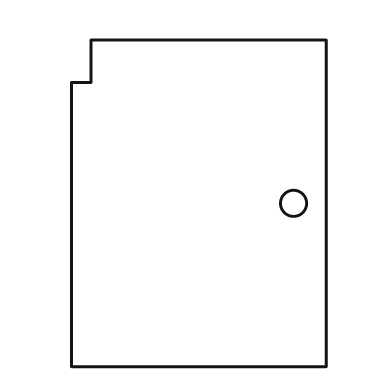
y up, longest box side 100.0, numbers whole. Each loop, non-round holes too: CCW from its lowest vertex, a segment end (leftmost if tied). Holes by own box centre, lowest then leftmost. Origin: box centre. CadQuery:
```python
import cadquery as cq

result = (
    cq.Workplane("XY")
    .moveTo(-39.0, -50.0)
    .lineTo(39.0, -50.0)
    .lineTo(39.0, 50.0)
    .lineTo(-33.0, 50.0)
    .lineTo(-33.0, 37.0)
    .lineTo(-39.0, 37.0)
    .close()
    .moveTo(29.0, 0.0)
    .circle(4.0)
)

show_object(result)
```